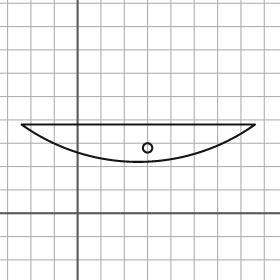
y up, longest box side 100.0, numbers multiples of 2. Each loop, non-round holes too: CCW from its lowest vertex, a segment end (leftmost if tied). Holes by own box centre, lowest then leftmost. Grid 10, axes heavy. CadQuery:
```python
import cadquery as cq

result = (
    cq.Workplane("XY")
    .moveTo(-24.0, 38.0)
    .threePointArc((26.0, 22.0), (76.0, 38.0))
    .close()
    .moveTo(30.0, 28.0)
    .circle(2.0)
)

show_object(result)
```